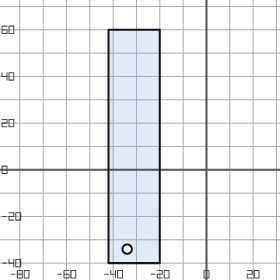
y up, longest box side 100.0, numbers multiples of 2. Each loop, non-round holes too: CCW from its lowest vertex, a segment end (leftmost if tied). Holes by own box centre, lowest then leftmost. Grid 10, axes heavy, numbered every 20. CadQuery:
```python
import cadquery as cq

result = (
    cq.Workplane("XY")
    .moveTo(-42.0, -40.0)
    .lineTo(-20.0, -40.0)
    .lineTo(-20.0, 60.0)
    .lineTo(-42.0, 60.0)
    .close()
    .moveTo(-34.0, -34.0)
    .circle(2.0)
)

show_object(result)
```